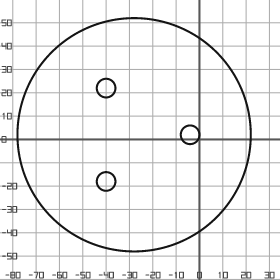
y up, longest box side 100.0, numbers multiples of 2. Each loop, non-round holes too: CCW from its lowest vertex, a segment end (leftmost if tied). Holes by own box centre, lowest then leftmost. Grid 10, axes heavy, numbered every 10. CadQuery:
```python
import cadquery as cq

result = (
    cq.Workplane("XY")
    .moveTo(-28.0, 2.0)
    .circle(50.0)
    .moveTo(-40.0, -18.0)
    .circle(4.0)
    .moveTo(-4.0, 2.0)
    .circle(4.0)
    .moveTo(-40.0, 22.0)
    .circle(4.0)
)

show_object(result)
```